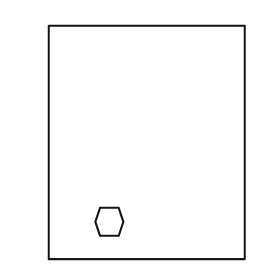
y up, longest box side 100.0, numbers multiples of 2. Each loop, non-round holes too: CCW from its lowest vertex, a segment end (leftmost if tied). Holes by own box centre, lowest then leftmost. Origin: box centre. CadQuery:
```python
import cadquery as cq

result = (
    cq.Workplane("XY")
    .moveTo(-42.0, -50.0)
    .lineTo(42.0, -50.0)
    .lineTo(42.0, 50.0)
    .lineTo(-42.0, 50.0)
    .close()
    .moveTo(-20.0, -40.0)
    .lineTo(-12.0, -40.0)
    .lineTo(-10.0, -34.0)
    .lineTo(-12.0, -28.0)
    .lineTo(-20.0, -28.0)
    .lineTo(-22.0, -34.0)
    .close()
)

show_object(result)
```